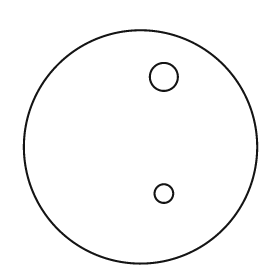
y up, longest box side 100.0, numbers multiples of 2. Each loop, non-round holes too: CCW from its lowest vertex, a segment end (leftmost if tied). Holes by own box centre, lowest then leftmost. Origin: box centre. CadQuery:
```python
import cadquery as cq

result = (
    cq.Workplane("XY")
    .moveTo(0.0, 0.0)
    .circle(50.0)
    .moveTo(10.0, -20.0)
    .circle(4.0)
    .moveTo(10.0, 30.0)
    .circle(6.0)
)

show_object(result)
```